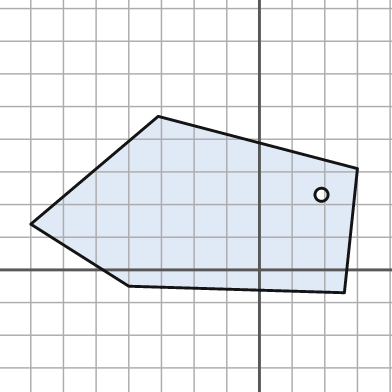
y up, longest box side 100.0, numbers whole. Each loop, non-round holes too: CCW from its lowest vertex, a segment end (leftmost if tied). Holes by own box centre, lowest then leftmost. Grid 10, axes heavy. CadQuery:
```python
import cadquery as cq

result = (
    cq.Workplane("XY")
    .moveTo(26.0, -7.0)
    .lineTo(30.0, 31.0)
    .lineTo(-31.0, 47.0)
    .lineTo(-70.0, 14.0)
    .lineTo(-40.0, -5.0)
    .close()
    .moveTo(19.0, 23.0)
    .circle(2.0)
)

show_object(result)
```